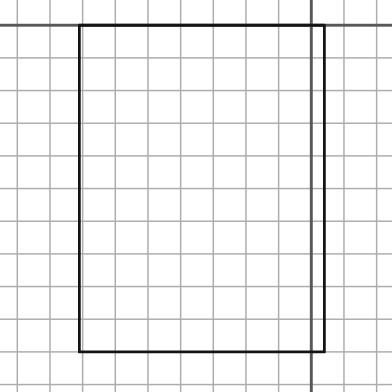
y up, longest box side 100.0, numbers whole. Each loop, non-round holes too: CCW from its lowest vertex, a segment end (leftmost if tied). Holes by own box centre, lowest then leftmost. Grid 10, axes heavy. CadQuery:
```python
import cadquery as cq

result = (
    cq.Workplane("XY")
    .moveTo(-71.0, -100.0)
    .lineTo(4.0, -100.0)
    .lineTo(4.0, 0.0)
    .lineTo(-71.0, 0.0)
    .close()
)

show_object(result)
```